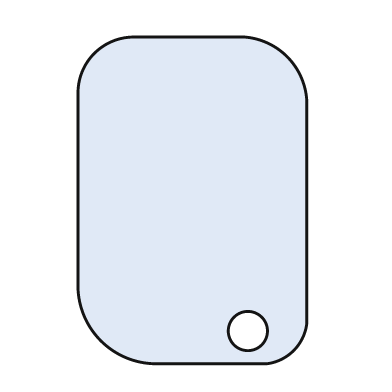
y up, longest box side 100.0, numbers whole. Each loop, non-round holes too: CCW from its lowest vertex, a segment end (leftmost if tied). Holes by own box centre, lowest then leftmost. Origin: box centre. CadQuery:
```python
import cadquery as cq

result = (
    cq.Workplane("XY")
    .moveTo(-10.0, -50.0)
    .lineTo(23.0, -50.0)
    .threePointArc((31.0, -46.0), (35.0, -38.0))
    .lineTo(35.0, 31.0)
    .threePointArc((29.0, 44.0), (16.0, 50.0))
    .lineTo(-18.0, 50.0)
    .threePointArc((-30.0, 45.0), (-35.0, 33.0))
    .lineTo(-35.0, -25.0)
    .threePointArc((-28.0, -43.0), (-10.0, -50.0))
    .close()
    .moveTo(17.0, -40.0)
    .circle(6.0)
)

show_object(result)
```